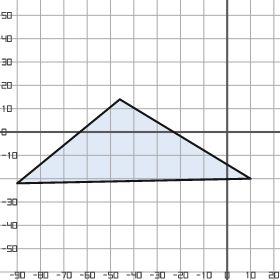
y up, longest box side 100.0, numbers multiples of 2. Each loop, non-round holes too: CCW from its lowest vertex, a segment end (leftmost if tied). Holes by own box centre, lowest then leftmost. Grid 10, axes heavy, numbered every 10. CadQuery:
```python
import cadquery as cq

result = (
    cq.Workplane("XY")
    .moveTo(-90.0, -22.0)
    .lineTo(10.0, -20.0)
    .lineTo(-46.0, 14.0)
    .close()
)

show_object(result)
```